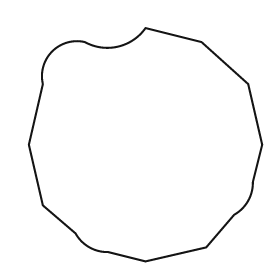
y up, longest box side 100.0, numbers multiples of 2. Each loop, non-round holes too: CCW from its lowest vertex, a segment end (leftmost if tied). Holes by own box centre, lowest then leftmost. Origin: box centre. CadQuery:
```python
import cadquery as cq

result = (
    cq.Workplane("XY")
    .moveTo(0.0, -50.0)
    .lineTo(26.0, -44.0)
    .lineTo(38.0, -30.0)
    .threePointArc((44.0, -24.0), (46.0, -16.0))
    .lineTo(50.0, 0.0)
    .lineTo(44.0, 26.0)
    .lineTo(24.0, 44.0)
    .lineTo(0.0, 50.0)
    .threePointArc((-12.0, 42.0), (-26.0, 44.0))
    .threePointArc((-40.0, 40.0), (-44.0, 26.0))
    .lineTo(-50.0, 0.0)
    .lineTo(-44.0, -26.0)
    .lineTo(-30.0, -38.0)
    .threePointArc((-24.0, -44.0), (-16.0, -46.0))
    .close()
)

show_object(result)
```